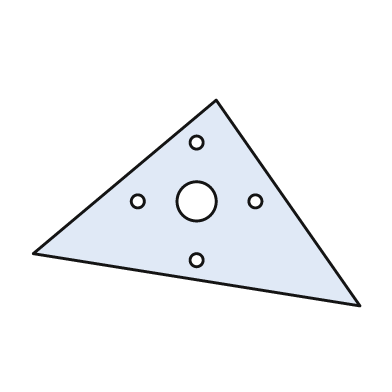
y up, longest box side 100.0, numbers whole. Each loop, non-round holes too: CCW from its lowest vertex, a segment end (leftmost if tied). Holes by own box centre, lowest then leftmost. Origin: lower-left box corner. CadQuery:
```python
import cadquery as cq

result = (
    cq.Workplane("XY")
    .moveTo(100.0, 0.0)
    .lineTo(56.0, 63.0)
    .lineTo(0.0, 16.0)
    .close()
    .moveTo(50.0, 14.0)
    .circle(2.0)
    .moveTo(32.0, 32.0)
    .circle(2.0)
    .moveTo(50.0, 32.0)
    .circle(6.0)
    .moveTo(68.0, 32.0)
    .circle(2.0)
    .moveTo(50.0, 50.0)
    .circle(2.0)
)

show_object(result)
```